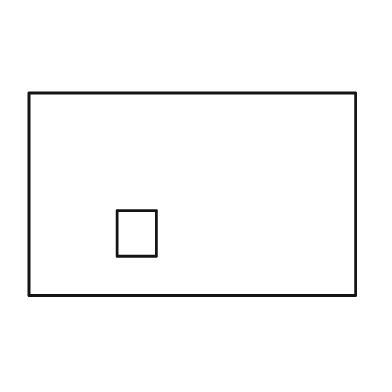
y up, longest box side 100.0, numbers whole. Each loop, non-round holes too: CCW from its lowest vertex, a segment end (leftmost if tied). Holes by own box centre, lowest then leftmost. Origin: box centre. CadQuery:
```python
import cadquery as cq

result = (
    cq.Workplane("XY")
    .moveTo(-50.0, -31.0)
    .lineTo(50.0, -31.0)
    .lineTo(50.0, 31.0)
    .lineTo(-50.0, 31.0)
    .close()
    .moveTo(-23.0, -19.0)
    .lineTo(-11.0, -19.0)
    .lineTo(-11.0, -5.0)
    .lineTo(-23.0, -5.0)
    .close()
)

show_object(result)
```